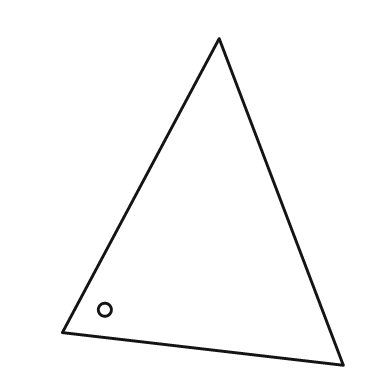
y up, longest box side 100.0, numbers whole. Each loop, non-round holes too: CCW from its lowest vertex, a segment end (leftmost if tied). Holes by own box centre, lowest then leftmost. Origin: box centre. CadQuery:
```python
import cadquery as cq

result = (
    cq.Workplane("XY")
    .moveTo(43.0, -50.0)
    .lineTo(5.0, 50.0)
    .lineTo(-43.0, -40.0)
    .close()
    .moveTo(-30.0, -33.0)
    .circle(2.0)
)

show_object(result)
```